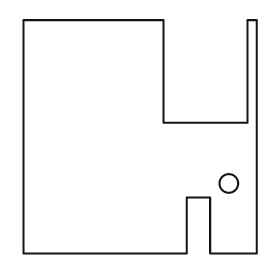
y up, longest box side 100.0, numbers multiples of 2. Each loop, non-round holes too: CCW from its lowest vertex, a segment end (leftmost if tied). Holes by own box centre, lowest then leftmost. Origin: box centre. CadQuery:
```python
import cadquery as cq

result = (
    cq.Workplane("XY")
    .moveTo(-50.0, -50.0)
    .lineTo(20.0, -50.0)
    .lineTo(20.0, -26.0)
    .lineTo(30.0, -26.0)
    .lineTo(30.0, -50.0)
    .lineTo(50.0, -50.0)
    .lineTo(50.0, 50.0)
    .lineTo(46.0, 50.0)
    .lineTo(46.0, 6.0)
    .lineTo(10.0, 6.0)
    .lineTo(10.0, 50.0)
    .lineTo(-50.0, 50.0)
    .close()
    .moveTo(38.0, -20.0)
    .circle(4.0)
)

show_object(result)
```